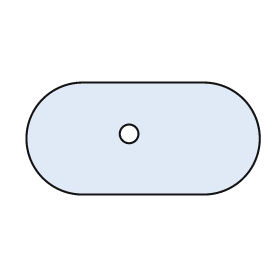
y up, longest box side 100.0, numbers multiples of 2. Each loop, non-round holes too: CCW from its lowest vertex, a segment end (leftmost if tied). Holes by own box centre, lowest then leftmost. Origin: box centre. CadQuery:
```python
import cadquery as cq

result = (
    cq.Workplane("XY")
    .moveTo(-26.0, -24.0)
    .lineTo(26.0, -24.0)
    .threePointArc((50.0, 0.0), (26.0, 24.0))
    .lineTo(-26.0, 24.0)
    .threePointArc((-50.0, 0.0), (-26.0, -24.0))
    .close()
    .moveTo(-6.0, 2.0)
    .circle(4.0)
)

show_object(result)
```